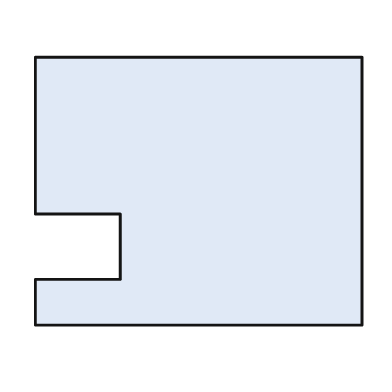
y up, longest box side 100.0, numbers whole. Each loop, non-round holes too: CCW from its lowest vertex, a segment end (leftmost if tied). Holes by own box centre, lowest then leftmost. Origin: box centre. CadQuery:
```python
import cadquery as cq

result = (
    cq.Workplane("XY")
    .moveTo(-50.0, -41.0)
    .lineTo(50.0, -41.0)
    .lineTo(50.0, 41.0)
    .lineTo(-50.0, 41.0)
    .lineTo(-50.0, -7.0)
    .lineTo(-24.0, -7.0)
    .lineTo(-24.0, -27.0)
    .lineTo(-50.0, -27.0)
    .close()
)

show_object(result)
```